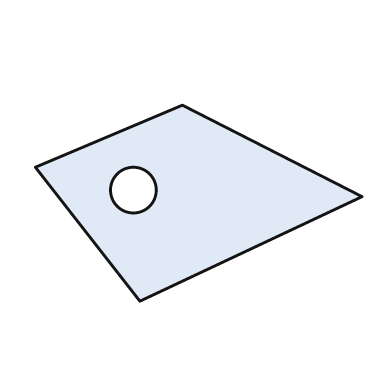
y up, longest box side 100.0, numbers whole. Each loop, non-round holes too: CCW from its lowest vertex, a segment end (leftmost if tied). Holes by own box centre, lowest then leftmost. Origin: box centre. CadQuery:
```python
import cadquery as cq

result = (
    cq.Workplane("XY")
    .moveTo(-18.0, -30.0)
    .lineTo(50.0, 2.0)
    .lineTo(-5.0, 30.0)
    .lineTo(-50.0, 11.0)
    .close()
    .moveTo(-20.0, 4.0)
    .circle(7.0)
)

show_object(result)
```